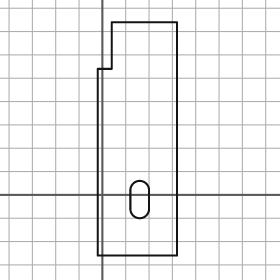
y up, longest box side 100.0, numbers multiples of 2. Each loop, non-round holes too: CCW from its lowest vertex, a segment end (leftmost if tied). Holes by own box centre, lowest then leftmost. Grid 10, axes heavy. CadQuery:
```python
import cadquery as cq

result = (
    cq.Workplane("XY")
    .moveTo(-2.0, -26.0)
    .lineTo(32.0, -26.0)
    .lineTo(32.0, 74.0)
    .lineTo(4.0, 74.0)
    .lineTo(4.0, 54.0)
    .lineTo(-2.0, 54.0)
    .close()
    .moveTo(12.0, -6.0)
    .threePointArc((16.0, -10.0), (20.0, -6.0))
    .lineTo(20.0, 2.0)
    .threePointArc((16.0, 6.0), (12.0, 2.0))
    .close()
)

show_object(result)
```